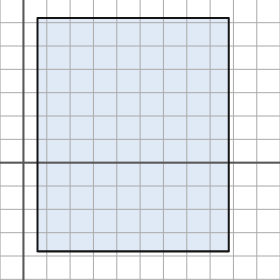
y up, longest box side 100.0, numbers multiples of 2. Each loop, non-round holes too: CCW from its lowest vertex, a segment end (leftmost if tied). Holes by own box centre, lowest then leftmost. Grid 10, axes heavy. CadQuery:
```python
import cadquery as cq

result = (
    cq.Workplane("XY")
    .moveTo(6.0, -38.0)
    .lineTo(88.0, -38.0)
    .lineTo(88.0, 62.0)
    .lineTo(6.0, 62.0)
    .close()
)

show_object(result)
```